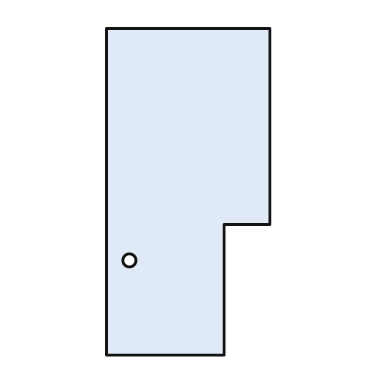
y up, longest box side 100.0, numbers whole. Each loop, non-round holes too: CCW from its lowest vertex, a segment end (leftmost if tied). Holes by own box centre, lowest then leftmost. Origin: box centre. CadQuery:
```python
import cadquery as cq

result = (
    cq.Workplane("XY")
    .moveTo(-25.0, -50.0)
    .lineTo(11.0, -50.0)
    .lineTo(11.0, -10.0)
    .lineTo(25.0, -10.0)
    .lineTo(25.0, 50.0)
    .lineTo(-25.0, 50.0)
    .close()
    .moveTo(-18.0, -21.0)
    .circle(2.0)
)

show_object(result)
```